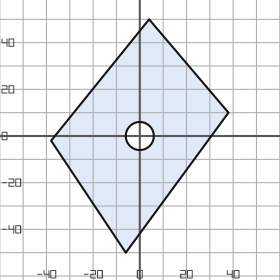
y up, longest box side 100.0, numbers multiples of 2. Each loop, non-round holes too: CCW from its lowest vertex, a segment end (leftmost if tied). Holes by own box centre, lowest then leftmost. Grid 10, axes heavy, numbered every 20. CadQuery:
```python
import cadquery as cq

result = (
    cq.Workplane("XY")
    .moveTo(-6.0, -50.0)
    .lineTo(38.0, 10.0)
    .lineTo(4.0, 50.0)
    .lineTo(-38.0, -2.0)
    .close()
    .moveTo(0.0, 0.0)
    .circle(6.0)
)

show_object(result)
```